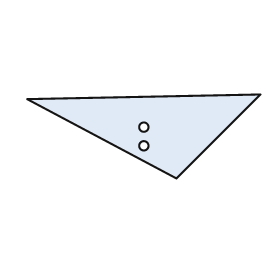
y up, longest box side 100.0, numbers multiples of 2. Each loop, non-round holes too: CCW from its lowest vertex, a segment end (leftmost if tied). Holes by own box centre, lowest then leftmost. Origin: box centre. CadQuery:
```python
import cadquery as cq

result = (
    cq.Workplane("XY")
    .moveTo(14.0, -18.0)
    .lineTo(50.0, 18.0)
    .lineTo(-50.0, 16.0)
    .close()
    .moveTo(0.0, -4.0)
    .circle(2.0)
    .moveTo(0.0, 4.0)
    .circle(2.0)
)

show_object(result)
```